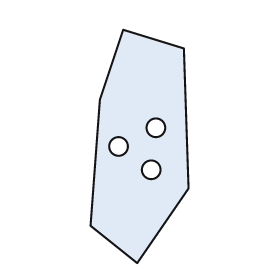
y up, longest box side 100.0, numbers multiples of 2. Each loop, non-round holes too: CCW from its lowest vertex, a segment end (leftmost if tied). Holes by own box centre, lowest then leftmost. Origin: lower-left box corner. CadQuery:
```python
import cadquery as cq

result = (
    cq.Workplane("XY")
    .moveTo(20.0, 0.0)
    .lineTo(42.0, 32.0)
    .lineTo(40.0, 92.0)
    .lineTo(14.0, 100.0)
    .lineTo(4.0, 70.0)
    .lineTo(0.0, 16.0)
    .close()
    .moveTo(26.0, 40.0)
    .circle(4.0)
    .moveTo(12.0, 50.0)
    .circle(4.0)
    .moveTo(28.0, 58.0)
    .circle(4.0)
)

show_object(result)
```